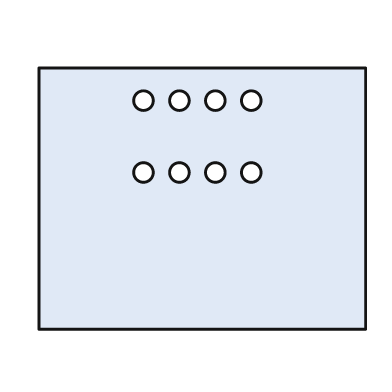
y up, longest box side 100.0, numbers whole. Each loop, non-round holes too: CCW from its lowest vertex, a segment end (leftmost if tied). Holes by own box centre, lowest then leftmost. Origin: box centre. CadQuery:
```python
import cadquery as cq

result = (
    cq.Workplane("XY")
    .moveTo(-50.0, -40.0)
    .lineTo(50.0, -40.0)
    .lineTo(50.0, 40.0)
    .lineTo(-50.0, 40.0)
    .close()
    .moveTo(-18.0, 8.0)
    .circle(3.0)
    .moveTo(-7.0, 8.0)
    .circle(3.0)
    .moveTo(4.0, 8.0)
    .circle(3.0)
    .moveTo(15.0, 8.0)
    .circle(3.0)
    .moveTo(-18.0, 30.0)
    .circle(3.0)
    .moveTo(-7.0, 30.0)
    .circle(3.0)
    .moveTo(4.0, 30.0)
    .circle(3.0)
    .moveTo(15.0, 30.0)
    .circle(3.0)
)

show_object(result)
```